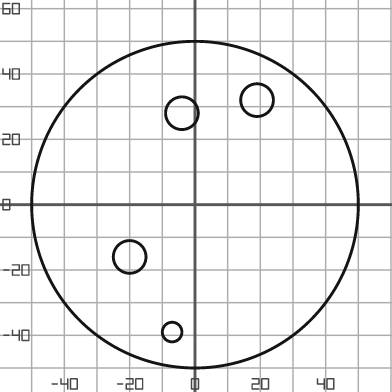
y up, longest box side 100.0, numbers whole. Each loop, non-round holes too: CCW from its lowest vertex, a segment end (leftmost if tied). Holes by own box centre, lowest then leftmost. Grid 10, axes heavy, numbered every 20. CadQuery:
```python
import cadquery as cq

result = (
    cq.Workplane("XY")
    .moveTo(0.0, 0.0)
    .circle(50.0)
    .moveTo(-7.0, -39.0)
    .circle(3.0)
    .moveTo(-20.0, -16.0)
    .circle(5.0)
    .moveTo(-4.0, 28.0)
    .circle(5.0)
    .moveTo(19.0, 32.0)
    .circle(5.0)
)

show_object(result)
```